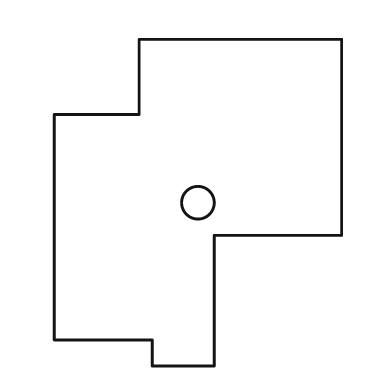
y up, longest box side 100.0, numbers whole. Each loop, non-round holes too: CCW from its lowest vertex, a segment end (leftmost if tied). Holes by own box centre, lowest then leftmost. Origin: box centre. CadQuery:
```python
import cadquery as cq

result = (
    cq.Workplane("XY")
    .moveTo(-14.0, -50.0)
    .lineTo(5.0, -50.0)
    .lineTo(5.0, -10.0)
    .lineTo(44.0, -10.0)
    .lineTo(44.0, 50.0)
    .lineTo(-18.0, 50.0)
    .lineTo(-18.0, 27.0)
    .lineTo(-44.0, 27.0)
    .lineTo(-44.0, -42.0)
    .lineTo(-14.0, -42.0)
    .close()
    .moveTo(0.0, 0.0)
    .circle(5.0)
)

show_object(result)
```